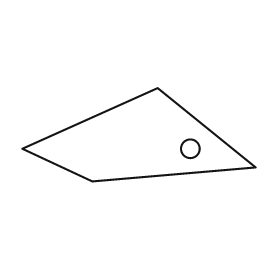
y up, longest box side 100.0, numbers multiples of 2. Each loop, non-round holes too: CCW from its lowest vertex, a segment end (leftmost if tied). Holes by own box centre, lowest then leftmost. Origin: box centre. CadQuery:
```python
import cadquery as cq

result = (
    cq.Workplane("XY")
    .moveTo(-20.0, -20.0)
    .lineTo(50.0, -14.0)
    .lineTo(8.0, 20.0)
    .lineTo(-50.0, -6.0)
    .close()
    .moveTo(22.0, -6.0)
    .circle(4.0)
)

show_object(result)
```